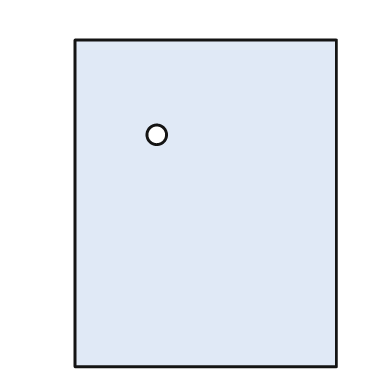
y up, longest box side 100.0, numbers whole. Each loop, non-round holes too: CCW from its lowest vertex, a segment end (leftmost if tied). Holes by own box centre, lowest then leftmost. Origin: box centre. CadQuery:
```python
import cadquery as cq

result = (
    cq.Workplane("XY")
    .moveTo(-40.0, -50.0)
    .lineTo(40.0, -50.0)
    .lineTo(40.0, 50.0)
    .lineTo(-40.0, 50.0)
    .close()
    .moveTo(-15.0, 21.0)
    .circle(3.0)
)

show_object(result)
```